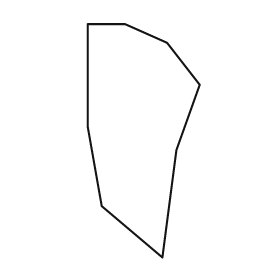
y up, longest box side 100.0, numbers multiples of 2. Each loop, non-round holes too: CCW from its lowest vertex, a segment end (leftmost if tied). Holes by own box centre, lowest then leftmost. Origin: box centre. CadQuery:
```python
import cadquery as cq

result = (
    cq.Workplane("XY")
    .moveTo(8.0, -50.0)
    .lineTo(14.0, -4.0)
    .lineTo(24.0, 24.0)
    .lineTo(10.0, 42.0)
    .lineTo(-8.0, 50.0)
    .lineTo(-24.0, 50.0)
    .lineTo(-24.0, 6.0)
    .lineTo(-18.0, -28.0)
    .close()
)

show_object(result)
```